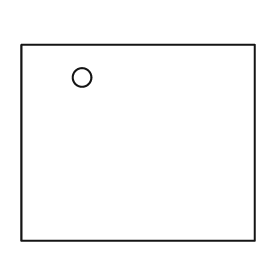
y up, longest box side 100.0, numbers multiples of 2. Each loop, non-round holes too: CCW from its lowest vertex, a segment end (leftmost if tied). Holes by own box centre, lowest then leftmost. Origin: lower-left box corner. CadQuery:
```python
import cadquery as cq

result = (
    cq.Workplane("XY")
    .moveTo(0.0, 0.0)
    .lineTo(100.0, 0.0)
    .lineTo(100.0, 84.0)
    .lineTo(0.0, 84.0)
    .close()
    .moveTo(26.0, 70.0)
    .circle(4.0)
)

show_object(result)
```